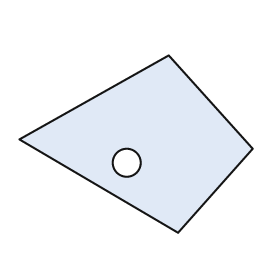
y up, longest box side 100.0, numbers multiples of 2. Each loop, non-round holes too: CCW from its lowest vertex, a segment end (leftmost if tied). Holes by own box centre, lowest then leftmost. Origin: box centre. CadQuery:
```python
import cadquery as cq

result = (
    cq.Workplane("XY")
    .moveTo(18.0, -38.0)
    .lineTo(50.0, -2.0)
    .lineTo(14.0, 38.0)
    .lineTo(-50.0, 2.0)
    .close()
    .moveTo(-4.0, -8.0)
    .circle(6.0)
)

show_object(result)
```